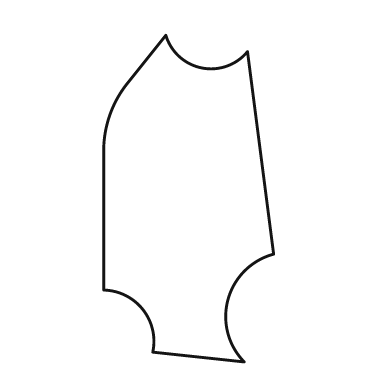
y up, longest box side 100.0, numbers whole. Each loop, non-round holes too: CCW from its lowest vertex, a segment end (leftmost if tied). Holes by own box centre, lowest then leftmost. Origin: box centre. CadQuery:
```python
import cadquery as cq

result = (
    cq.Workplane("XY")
    .moveTo(17.0, -50.0)
    .threePointArc((12.0, -31.0), (26.0, -17.0))
    .lineTo(18.0, 45.0)
    .threePointArc((4.0, 40.0), (-7.0, 50.0))
    .lineTo(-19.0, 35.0)
    .threePointArc((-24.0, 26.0), (-26.0, 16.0))
    .lineTo(-26.0, -28.0)
    .threePointArc((-14.0, -34.0), (-11.0, -47.0))
    .close()
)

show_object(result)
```